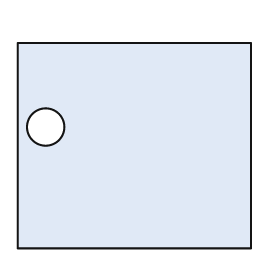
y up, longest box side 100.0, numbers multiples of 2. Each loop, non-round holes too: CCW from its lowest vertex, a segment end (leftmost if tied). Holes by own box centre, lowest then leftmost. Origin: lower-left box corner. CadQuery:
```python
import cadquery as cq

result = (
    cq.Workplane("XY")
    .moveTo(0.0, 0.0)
    .lineTo(100.0, 0.0)
    .lineTo(100.0, 88.0)
    .lineTo(0.0, 88.0)
    .close()
    .moveTo(12.0, 52.0)
    .circle(8.0)
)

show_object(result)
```